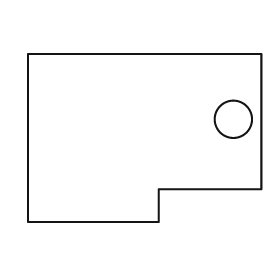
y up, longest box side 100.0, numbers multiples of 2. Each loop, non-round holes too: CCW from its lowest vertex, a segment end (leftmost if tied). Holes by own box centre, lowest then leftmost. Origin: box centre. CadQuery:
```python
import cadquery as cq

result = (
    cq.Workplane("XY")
    .moveTo(-50.0, -36.0)
    .lineTo(6.0, -36.0)
    .lineTo(6.0, -22.0)
    .lineTo(50.0, -22.0)
    .lineTo(50.0, 36.0)
    .lineTo(-50.0, 36.0)
    .close()
    .moveTo(38.0, 8.0)
    .circle(8.0)
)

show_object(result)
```